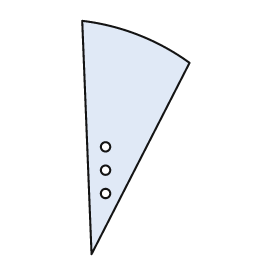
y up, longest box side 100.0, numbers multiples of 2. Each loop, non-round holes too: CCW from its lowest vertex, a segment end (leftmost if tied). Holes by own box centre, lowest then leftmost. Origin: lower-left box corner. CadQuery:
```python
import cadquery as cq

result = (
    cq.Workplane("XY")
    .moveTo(4.0, 0.0)
    .lineTo(46.0, 82.0)
    .threePointArc((24.0, 94.0), (0.0, 100.0))
    .close()
    .moveTo(10.0, 26.0)
    .circle(2.0)
    .moveTo(10.0, 36.0)
    .circle(2.0)
    .moveTo(10.0, 46.0)
    .circle(2.0)
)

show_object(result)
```